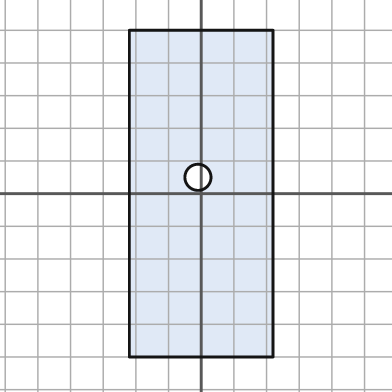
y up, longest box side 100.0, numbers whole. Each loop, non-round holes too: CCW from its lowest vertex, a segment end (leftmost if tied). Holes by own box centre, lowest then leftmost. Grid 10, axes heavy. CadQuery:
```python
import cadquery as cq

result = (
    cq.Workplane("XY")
    .moveTo(-22.0, -50.0)
    .lineTo(22.0, -50.0)
    .lineTo(22.0, 50.0)
    .lineTo(-22.0, 50.0)
    .close()
    .moveTo(-1.0, 5.0)
    .circle(4.0)
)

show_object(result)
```